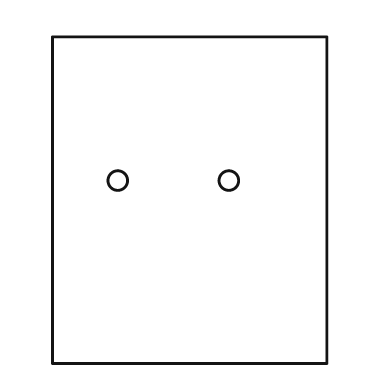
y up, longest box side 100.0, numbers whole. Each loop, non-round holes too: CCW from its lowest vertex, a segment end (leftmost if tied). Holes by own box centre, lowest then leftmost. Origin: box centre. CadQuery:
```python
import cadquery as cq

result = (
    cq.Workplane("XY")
    .moveTo(-42.0, -50.0)
    .lineTo(42.0, -50.0)
    .lineTo(42.0, 50.0)
    .lineTo(-42.0, 50.0)
    .close()
    .moveTo(-22.0, 6.0)
    .circle(3.0)
    .moveTo(12.0, 6.0)
    .circle(3.0)
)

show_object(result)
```